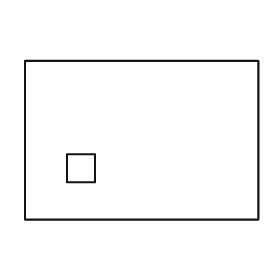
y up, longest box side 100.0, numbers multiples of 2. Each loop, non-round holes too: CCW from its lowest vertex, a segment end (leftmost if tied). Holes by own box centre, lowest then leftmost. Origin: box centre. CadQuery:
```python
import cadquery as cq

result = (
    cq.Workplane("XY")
    .moveTo(-50.0, -34.0)
    .lineTo(50.0, -34.0)
    .lineTo(50.0, 34.0)
    .lineTo(-50.0, 34.0)
    .close()
    .moveTo(-32.0, -18.0)
    .lineTo(-20.0, -18.0)
    .lineTo(-20.0, -6.0)
    .lineTo(-32.0, -6.0)
    .close()
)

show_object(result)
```